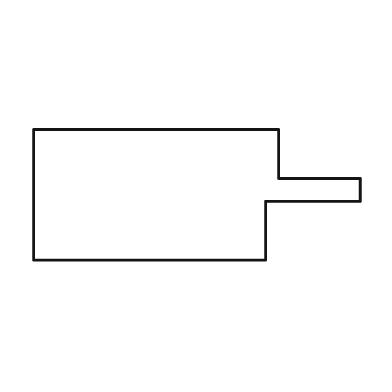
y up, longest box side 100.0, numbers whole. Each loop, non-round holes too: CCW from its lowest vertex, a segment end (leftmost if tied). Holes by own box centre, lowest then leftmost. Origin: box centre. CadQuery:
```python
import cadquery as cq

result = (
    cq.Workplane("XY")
    .moveTo(-50.0, -20.0)
    .lineTo(21.0, -20.0)
    .lineTo(21.0, -2.0)
    .lineTo(50.0, -2.0)
    .lineTo(50.0, 5.0)
    .lineTo(25.0, 5.0)
    .lineTo(25.0, 20.0)
    .lineTo(-50.0, 20.0)
    .close()
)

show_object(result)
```